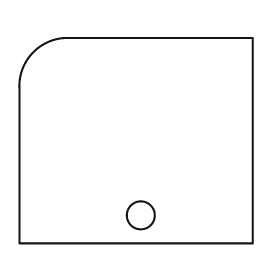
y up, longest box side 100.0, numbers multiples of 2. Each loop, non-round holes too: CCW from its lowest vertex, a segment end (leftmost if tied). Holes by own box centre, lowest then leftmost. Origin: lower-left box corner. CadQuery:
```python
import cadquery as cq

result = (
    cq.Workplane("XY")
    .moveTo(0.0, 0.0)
    .lineTo(100.0, 0.0)
    .lineTo(100.0, 88.0)
    .lineTo(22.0, 88.0)
    .threePointArc((6.0, 82.0), (0.0, 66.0))
    .close()
    .moveTo(52.0, 12.0)
    .circle(6.0)
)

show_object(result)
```